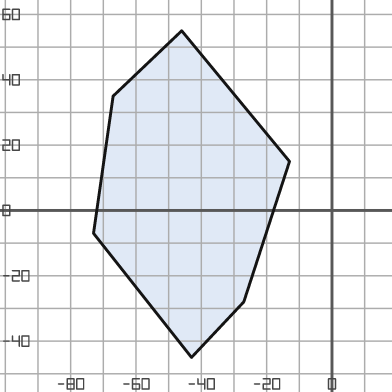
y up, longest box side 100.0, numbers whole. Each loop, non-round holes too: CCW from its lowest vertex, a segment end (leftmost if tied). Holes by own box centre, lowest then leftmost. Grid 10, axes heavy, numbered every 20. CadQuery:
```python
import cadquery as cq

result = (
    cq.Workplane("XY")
    .moveTo(-43.0, -45.0)
    .lineTo(-27.0, -28.0)
    .lineTo(-13.0, 15.0)
    .lineTo(-46.0, 55.0)
    .lineTo(-67.0, 35.0)
    .lineTo(-73.0, -7.0)
    .close()
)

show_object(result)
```